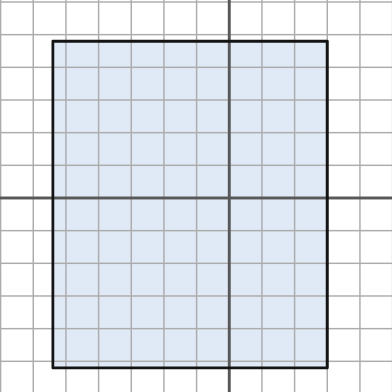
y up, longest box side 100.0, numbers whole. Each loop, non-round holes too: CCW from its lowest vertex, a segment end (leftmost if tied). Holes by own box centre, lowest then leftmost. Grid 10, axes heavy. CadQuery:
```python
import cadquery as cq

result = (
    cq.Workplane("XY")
    .moveTo(-54.0, -52.0)
    .lineTo(30.0, -52.0)
    .lineTo(30.0, 48.0)
    .lineTo(-54.0, 48.0)
    .close()
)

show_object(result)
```